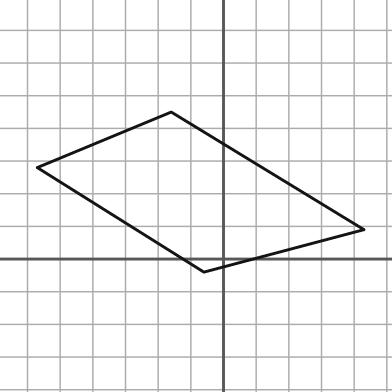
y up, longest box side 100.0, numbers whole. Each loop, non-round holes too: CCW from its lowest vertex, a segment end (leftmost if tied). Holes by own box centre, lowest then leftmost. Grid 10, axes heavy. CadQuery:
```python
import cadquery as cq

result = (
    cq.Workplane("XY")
    .moveTo(-6.0, -4.0)
    .lineTo(43.0, 9.0)
    .lineTo(-16.0, 45.0)
    .lineTo(-57.0, 28.0)
    .close()
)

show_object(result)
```